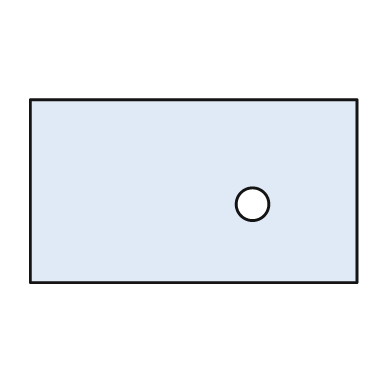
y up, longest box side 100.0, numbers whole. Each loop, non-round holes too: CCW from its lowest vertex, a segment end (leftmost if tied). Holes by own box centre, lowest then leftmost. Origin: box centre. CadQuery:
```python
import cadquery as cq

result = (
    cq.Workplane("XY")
    .moveTo(-50.0, -28.0)
    .lineTo(50.0, -28.0)
    .lineTo(50.0, 28.0)
    .lineTo(-50.0, 28.0)
    .close()
    .moveTo(18.0, -4.0)
    .circle(5.0)
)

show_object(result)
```